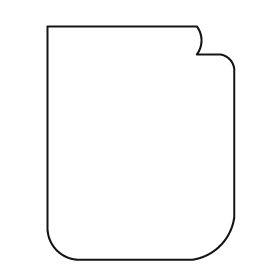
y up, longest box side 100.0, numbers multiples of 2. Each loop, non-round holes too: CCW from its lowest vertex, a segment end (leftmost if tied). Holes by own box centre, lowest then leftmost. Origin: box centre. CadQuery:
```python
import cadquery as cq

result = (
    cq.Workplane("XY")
    .moveTo(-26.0, -50.0)
    .lineTo(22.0, -50.0)
    .threePointArc((34.0, -44.0), (40.0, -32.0))
    .lineTo(40.0, 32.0)
    .threePointArc((38.0, 36.0), (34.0, 38.0))
    .lineTo(24.0, 38.0)
    .threePointArc((26.0, 44.0), (24.0, 50.0))
    .lineTo(-40.0, 50.0)
    .lineTo(-40.0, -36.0)
    .threePointArc((-36.0, -46.0), (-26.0, -50.0))
    .close()
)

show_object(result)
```